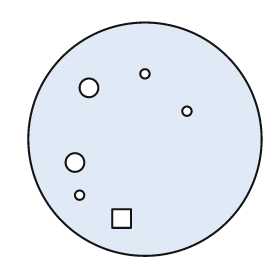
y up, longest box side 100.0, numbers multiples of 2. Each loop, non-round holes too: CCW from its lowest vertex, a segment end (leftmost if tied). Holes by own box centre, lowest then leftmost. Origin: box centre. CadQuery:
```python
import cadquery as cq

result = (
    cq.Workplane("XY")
    .moveTo(0.0, 0.0)
    .circle(50.0)
    .moveTo(-14.0, -38.0)
    .lineTo(-6.0, -38.0)
    .lineTo(-6.0, -30.0)
    .lineTo(-14.0, -30.0)
    .close()
    .moveTo(-28.0, -24.0)
    .circle(2.0)
    .moveTo(-30.0, -10.0)
    .circle(4.0)
    .moveTo(18.0, 12.0)
    .circle(2.0)
    .moveTo(-24.0, 22.0)
    .circle(4.0)
    .moveTo(0.0, 28.0)
    .circle(2.0)
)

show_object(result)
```